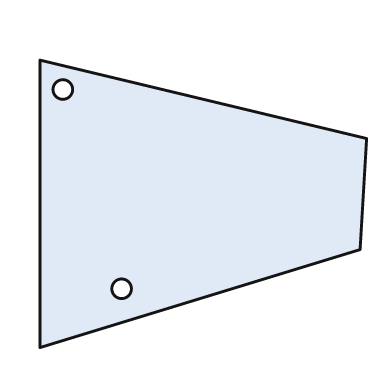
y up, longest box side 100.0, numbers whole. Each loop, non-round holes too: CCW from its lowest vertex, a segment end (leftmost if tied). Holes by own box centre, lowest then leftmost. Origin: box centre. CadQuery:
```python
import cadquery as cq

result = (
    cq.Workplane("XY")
    .moveTo(-50.0, -44.0)
    .lineTo(48.0, -14.0)
    .lineTo(50.0, 20.0)
    .lineTo(-50.0, 44.0)
    .close()
    .moveTo(-25.0, -26.0)
    .circle(3.0)
    .moveTo(-43.0, 35.0)
    .circle(3.0)
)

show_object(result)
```